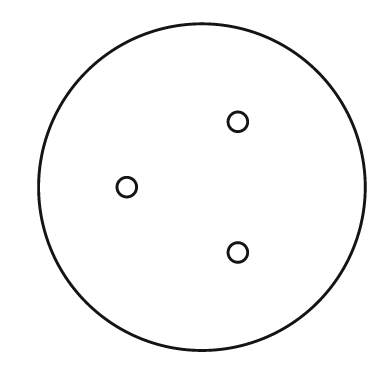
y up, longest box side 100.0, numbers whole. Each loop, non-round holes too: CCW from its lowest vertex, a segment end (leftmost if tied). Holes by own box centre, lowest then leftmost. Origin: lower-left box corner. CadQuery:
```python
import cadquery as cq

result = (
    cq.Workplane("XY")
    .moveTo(50.0, 50.0)
    .circle(50.0)
    .moveTo(61.0, 30.0)
    .circle(3.0)
    .moveTo(27.0, 50.0)
    .circle(3.0)
    .moveTo(61.0, 70.0)
    .circle(3.0)
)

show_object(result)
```